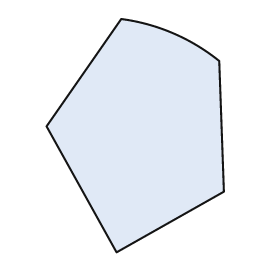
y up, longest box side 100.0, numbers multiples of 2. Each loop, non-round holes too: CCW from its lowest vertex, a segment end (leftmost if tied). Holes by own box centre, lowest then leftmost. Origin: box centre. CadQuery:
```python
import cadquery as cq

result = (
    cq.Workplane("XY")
    .moveTo(-8.0, -50.0)
    .lineTo(38.0, -24.0)
    .lineTo(36.0, 32.0)
    .threePointArc((16.0, 44.0), (-6.0, 50.0))
    .lineTo(-38.0, 4.0)
    .close()
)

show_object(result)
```